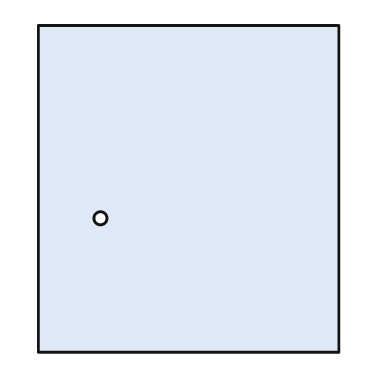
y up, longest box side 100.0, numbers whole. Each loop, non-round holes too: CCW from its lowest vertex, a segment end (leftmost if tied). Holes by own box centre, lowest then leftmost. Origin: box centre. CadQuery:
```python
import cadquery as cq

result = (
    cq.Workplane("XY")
    .moveTo(-46.0, -50.0)
    .lineTo(46.0, -50.0)
    .lineTo(46.0, 50.0)
    .lineTo(-46.0, 50.0)
    .close()
    .moveTo(-27.0, -9.0)
    .circle(2.0)
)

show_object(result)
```